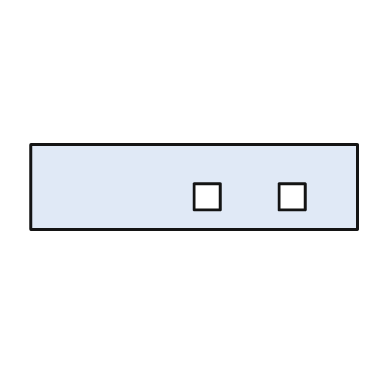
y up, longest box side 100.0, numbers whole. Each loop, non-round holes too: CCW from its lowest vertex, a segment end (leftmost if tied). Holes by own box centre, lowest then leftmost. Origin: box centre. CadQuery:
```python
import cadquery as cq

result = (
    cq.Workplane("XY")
    .moveTo(-50.0, -13.0)
    .lineTo(50.0, -13.0)
    .lineTo(50.0, 13.0)
    .lineTo(-50.0, 13.0)
    .close()
    .moveTo(0.0, -7.0)
    .lineTo(8.0, -7.0)
    .lineTo(8.0, 1.0)
    .lineTo(0.0, 1.0)
    .close()
    .moveTo(26.0, -7.0)
    .lineTo(34.0, -7.0)
    .lineTo(34.0, 1.0)
    .lineTo(26.0, 1.0)
    .close()
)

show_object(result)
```